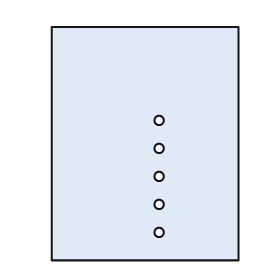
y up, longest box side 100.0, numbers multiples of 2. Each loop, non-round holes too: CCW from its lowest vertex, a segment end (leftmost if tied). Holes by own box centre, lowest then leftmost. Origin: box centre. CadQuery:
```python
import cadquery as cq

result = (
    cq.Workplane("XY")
    .moveTo(-40.0, -50.0)
    .lineTo(40.0, -50.0)
    .lineTo(40.0, 50.0)
    .lineTo(-40.0, 50.0)
    .close()
    .moveTo(6.0, -38.0)
    .circle(2.0)
    .moveTo(6.0, -26.0)
    .circle(2.0)
    .moveTo(6.0, -14.0)
    .circle(2.0)
    .moveTo(6.0, -2.0)
    .circle(2.0)
    .moveTo(6.0, 10.0)
    .circle(2.0)
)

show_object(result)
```